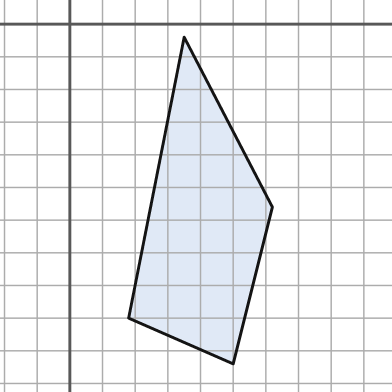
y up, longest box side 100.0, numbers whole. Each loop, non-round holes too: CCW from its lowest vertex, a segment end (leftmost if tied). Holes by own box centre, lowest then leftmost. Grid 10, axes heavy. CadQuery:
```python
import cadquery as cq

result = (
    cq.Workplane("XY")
    .moveTo(50.0, -104.0)
    .lineTo(62.0, -56.0)
    .lineTo(35.0, -4.0)
    .lineTo(18.0, -90.0)
    .close()
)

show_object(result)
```